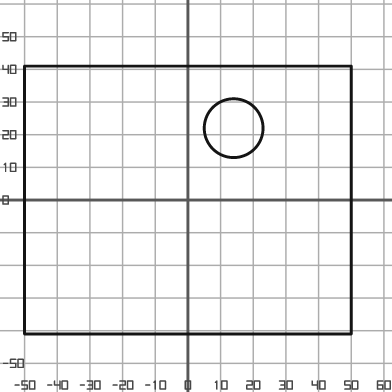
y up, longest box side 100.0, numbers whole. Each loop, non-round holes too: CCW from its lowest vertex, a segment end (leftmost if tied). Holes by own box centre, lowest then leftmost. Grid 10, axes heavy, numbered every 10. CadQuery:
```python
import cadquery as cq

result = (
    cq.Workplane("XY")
    .moveTo(-50.0, -41.0)
    .lineTo(50.0, -41.0)
    .lineTo(50.0, 41.0)
    .lineTo(-50.0, 41.0)
    .close()
    .moveTo(14.0, 22.0)
    .circle(9.0)
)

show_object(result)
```